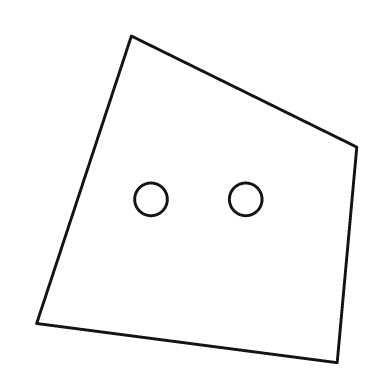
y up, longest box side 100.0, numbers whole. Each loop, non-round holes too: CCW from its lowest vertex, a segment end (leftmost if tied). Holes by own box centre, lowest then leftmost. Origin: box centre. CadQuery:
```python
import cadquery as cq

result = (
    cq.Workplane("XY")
    .moveTo(43.0, -50.0)
    .lineTo(49.0, 16.0)
    .lineTo(-20.0, 50.0)
    .lineTo(-49.0, -38.0)
    .close()
    .moveTo(-14.0, 0.0)
    .circle(5.0)
    .moveTo(15.0, 0.0)
    .circle(5.0)
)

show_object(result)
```